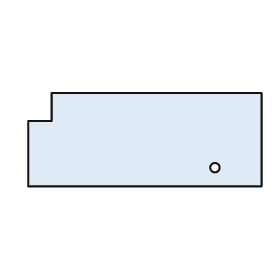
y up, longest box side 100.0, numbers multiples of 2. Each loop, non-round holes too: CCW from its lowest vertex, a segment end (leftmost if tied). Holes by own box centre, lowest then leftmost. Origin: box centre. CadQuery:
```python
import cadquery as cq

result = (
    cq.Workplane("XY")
    .moveTo(-50.0, -20.0)
    .lineTo(50.0, -20.0)
    .lineTo(50.0, 20.0)
    .lineTo(-40.0, 20.0)
    .lineTo(-40.0, 8.0)
    .lineTo(-50.0, 8.0)
    .close()
    .moveTo(30.0, -12.0)
    .circle(2.0)
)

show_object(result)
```